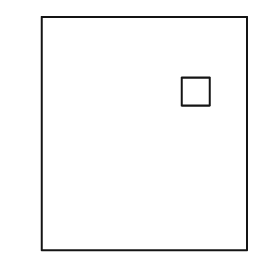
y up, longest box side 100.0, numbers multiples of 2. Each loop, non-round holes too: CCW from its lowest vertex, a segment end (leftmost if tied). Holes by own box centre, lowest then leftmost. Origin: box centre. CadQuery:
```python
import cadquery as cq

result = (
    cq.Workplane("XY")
    .moveTo(-44.0, -50.0)
    .lineTo(44.0, -50.0)
    .lineTo(44.0, 50.0)
    .lineTo(-44.0, 50.0)
    .close()
    .moveTo(16.0, 12.0)
    .lineTo(28.0, 12.0)
    .lineTo(28.0, 24.0)
    .lineTo(16.0, 24.0)
    .close()
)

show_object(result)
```